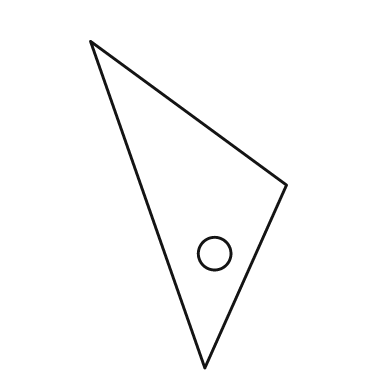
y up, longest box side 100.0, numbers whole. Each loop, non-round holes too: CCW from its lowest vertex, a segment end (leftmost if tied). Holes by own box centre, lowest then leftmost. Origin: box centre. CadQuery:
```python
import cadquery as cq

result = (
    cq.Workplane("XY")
    .moveTo(5.0, -50.0)
    .lineTo(30.0, 6.0)
    .lineTo(-30.0, 50.0)
    .close()
    .moveTo(8.0, -15.0)
    .circle(5.0)
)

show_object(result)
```